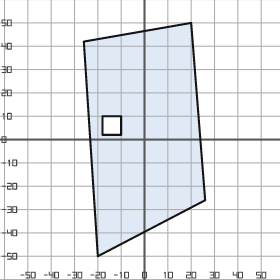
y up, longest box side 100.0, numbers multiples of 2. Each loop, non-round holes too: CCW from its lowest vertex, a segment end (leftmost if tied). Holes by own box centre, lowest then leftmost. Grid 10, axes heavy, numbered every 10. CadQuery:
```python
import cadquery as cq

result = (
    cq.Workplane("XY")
    .moveTo(-20.0, -50.0)
    .lineTo(26.0, -26.0)
    .lineTo(20.0, 50.0)
    .lineTo(-26.0, 42.0)
    .close()
    .moveTo(-18.0, 2.0)
    .lineTo(-10.0, 2.0)
    .lineTo(-10.0, 10.0)
    .lineTo(-18.0, 10.0)
    .close()
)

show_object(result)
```